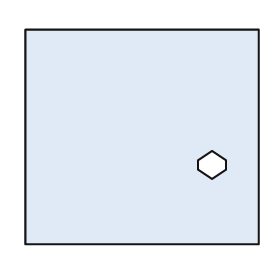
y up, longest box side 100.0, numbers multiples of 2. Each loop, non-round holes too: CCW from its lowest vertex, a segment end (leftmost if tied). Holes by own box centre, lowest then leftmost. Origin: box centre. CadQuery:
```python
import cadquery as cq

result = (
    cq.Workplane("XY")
    .moveTo(-50.0, -46.0)
    .lineTo(50.0, -46.0)
    .lineTo(50.0, 46.0)
    .lineTo(-50.0, 46.0)
    .close()
    .moveTo(30.0, -18.0)
    .lineTo(36.0, -14.0)
    .lineTo(36.0, -10.0)
    .lineTo(30.0, -6.0)
    .lineTo(24.0, -10.0)
    .lineTo(24.0, -14.0)
    .close()
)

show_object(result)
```